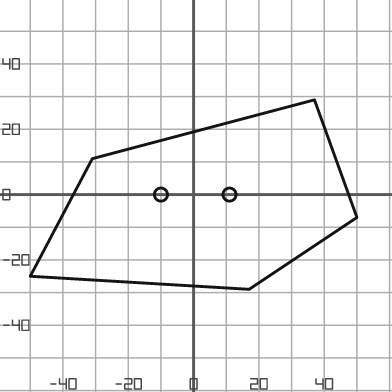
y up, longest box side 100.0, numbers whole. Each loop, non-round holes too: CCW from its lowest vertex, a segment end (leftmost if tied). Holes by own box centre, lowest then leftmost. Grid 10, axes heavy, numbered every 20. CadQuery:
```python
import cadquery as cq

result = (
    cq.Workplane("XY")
    .moveTo(17.0, -29.0)
    .lineTo(50.0, -7.0)
    .lineTo(37.0, 29.0)
    .lineTo(-31.0, 11.0)
    .lineTo(-50.0, -25.0)
    .close()
    .moveTo(-10.0, 0.0)
    .circle(2.0)
    .moveTo(11.0, 0.0)
    .circle(2.0)
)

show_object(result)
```